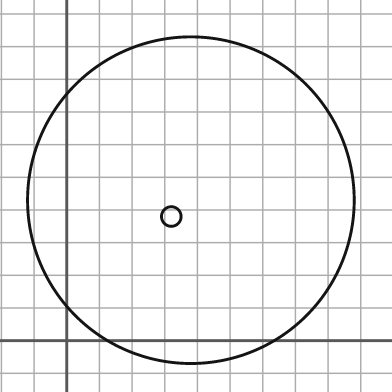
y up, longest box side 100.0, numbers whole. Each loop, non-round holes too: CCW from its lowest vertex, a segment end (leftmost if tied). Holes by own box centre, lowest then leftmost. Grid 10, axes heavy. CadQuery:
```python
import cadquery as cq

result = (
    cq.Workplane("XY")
    .moveTo(38.0, 43.0)
    .circle(50.0)
    .moveTo(32.0, 38.0)
    .circle(3.0)
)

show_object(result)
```